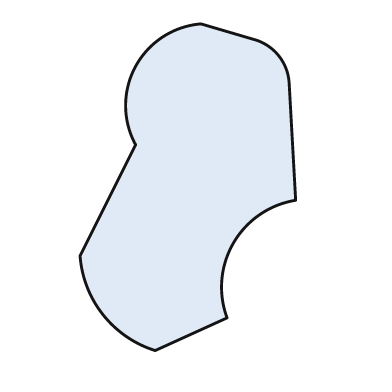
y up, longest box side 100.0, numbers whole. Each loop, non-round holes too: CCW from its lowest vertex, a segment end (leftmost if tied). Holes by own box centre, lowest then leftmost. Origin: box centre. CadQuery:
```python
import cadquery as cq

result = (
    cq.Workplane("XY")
    .moveTo(-10.0, -50.0)
    .lineTo(12.0, -40.0)
    .threePointArc((14.0, -17.0), (33.0, -4.0))
    .lineTo(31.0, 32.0)
    .threePointArc((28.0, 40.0), (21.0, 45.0))
    .lineTo(4.0, 50.0)
    .threePointArc((-16.0, 37.0), (-16.0, 13.0))
    .lineTo(-33.0, -21.0)
    .threePointArc((-26.0, -39.0), (-10.0, -50.0))
    .close()
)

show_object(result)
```